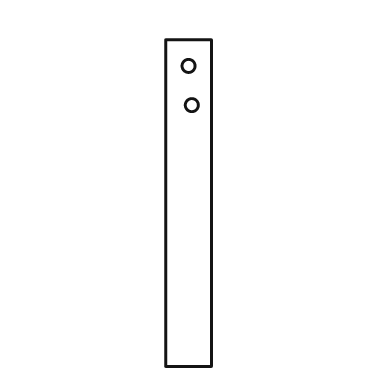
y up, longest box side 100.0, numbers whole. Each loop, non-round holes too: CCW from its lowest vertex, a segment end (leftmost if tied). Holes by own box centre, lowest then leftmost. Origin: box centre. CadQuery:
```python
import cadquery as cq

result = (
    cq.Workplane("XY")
    .moveTo(-7.0, -50.0)
    .lineTo(7.0, -50.0)
    .lineTo(7.0, 50.0)
    .lineTo(-7.0, 50.0)
    .close()
    .moveTo(1.0, 30.0)
    .circle(2.0)
    .moveTo(0.0, 42.0)
    .circle(2.0)
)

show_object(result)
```